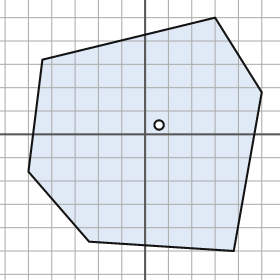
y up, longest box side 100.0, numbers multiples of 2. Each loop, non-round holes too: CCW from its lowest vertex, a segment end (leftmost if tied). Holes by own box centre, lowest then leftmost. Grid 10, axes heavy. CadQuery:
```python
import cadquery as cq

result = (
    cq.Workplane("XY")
    .moveTo(38.0, -50.0)
    .lineTo(50.0, 18.0)
    .lineTo(30.0, 50.0)
    .lineTo(-44.0, 32.0)
    .lineTo(-50.0, -16.0)
    .lineTo(-24.0, -46.0)
    .close()
    .moveTo(6.0, 4.0)
    .circle(2.0)
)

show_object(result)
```